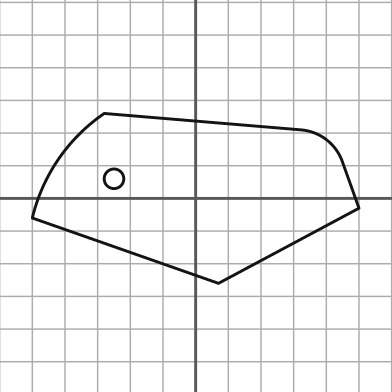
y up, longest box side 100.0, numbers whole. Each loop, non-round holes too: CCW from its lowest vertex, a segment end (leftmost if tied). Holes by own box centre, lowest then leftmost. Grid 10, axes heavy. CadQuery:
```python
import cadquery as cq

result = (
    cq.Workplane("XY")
    .moveTo(7.0, -26.0)
    .lineTo(50.0, -3.0)
    .lineTo(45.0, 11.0)
    .threePointArc((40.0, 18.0), (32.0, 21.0))
    .lineTo(-28.0, 26.0)
    .threePointArc((-42.0, 12.0), (-50.0, -6.0))
    .close()
    .moveTo(-25.0, 6.0)
    .circle(3.0)
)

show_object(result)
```